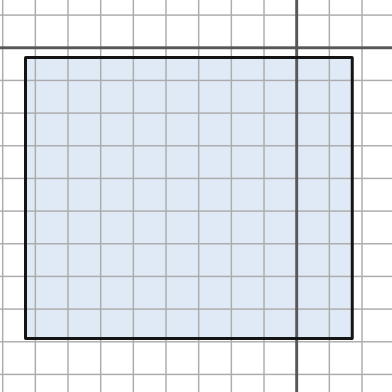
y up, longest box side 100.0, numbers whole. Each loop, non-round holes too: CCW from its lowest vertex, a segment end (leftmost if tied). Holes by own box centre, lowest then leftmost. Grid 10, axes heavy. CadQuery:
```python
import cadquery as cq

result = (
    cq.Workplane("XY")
    .moveTo(-83.0, -89.0)
    .lineTo(17.0, -89.0)
    .lineTo(17.0, -3.0)
    .lineTo(-83.0, -3.0)
    .close()
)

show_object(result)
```